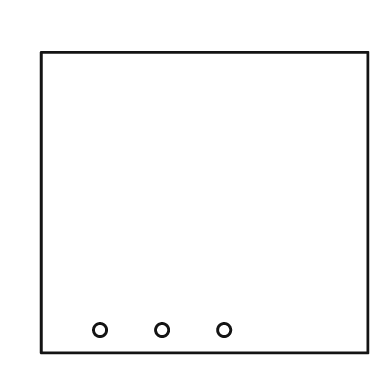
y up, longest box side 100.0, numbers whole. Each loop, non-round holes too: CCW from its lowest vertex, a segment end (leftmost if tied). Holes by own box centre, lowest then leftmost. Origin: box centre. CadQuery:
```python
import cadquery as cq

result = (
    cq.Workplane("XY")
    .moveTo(-50.0, -46.0)
    .lineTo(50.0, -46.0)
    .lineTo(50.0, 46.0)
    .lineTo(-50.0, 46.0)
    .close()
    .moveTo(-32.0, -39.0)
    .circle(2.0)
    .moveTo(-13.0, -39.0)
    .circle(2.0)
    .moveTo(6.0, -39.0)
    .circle(2.0)
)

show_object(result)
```